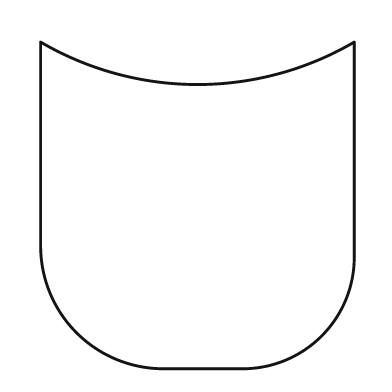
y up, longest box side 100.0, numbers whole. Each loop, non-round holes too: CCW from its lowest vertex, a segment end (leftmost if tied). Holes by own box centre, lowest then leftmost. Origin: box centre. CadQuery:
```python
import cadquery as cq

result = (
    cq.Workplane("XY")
    .moveTo(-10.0, -50.0)
    .lineTo(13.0, -50.0)
    .threePointArc((38.0, -40.0), (48.0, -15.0))
    .lineTo(48.0, 50.0)
    .threePointArc((0.0, 37.0), (-48.0, 50.0))
    .lineTo(-48.0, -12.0)
    .threePointArc((-37.0, -39.0), (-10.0, -50.0))
    .close()
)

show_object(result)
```